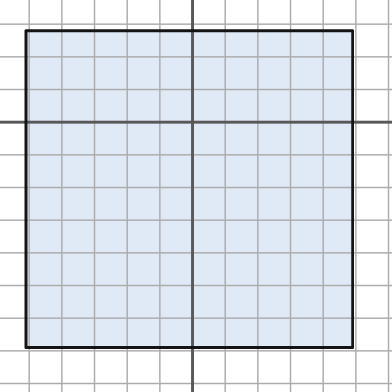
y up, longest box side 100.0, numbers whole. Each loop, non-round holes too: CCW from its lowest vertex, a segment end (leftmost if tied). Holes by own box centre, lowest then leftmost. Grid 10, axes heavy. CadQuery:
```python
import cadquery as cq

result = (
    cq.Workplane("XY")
    .moveTo(-51.0, -69.0)
    .lineTo(49.0, -69.0)
    .lineTo(49.0, 28.0)
    .lineTo(-51.0, 28.0)
    .close()
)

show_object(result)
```